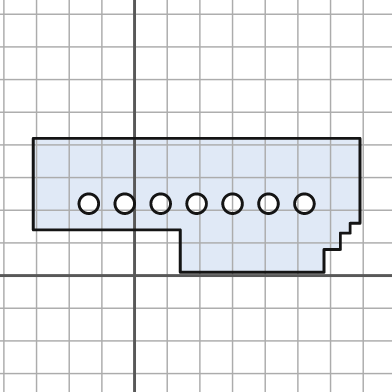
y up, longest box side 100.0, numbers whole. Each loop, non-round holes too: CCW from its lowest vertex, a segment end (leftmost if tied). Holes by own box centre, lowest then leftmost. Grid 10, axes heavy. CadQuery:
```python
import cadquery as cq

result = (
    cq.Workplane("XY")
    .moveTo(14.0, 1.0)
    .lineTo(58.0, 1.0)
    .lineTo(58.0, 8.0)
    .lineTo(63.0, 8.0)
    .lineTo(63.0, 13.0)
    .lineTo(66.0, 13.0)
    .lineTo(66.0, 16.0)
    .lineTo(69.0, 16.0)
    .lineTo(69.0, 42.0)
    .lineTo(-31.0, 42.0)
    .lineTo(-31.0, 14.0)
    .lineTo(14.0, 14.0)
    .close()
    .moveTo(-14.0, 22.0)
    .circle(3.0)
    .moveTo(-3.0, 22.0)
    .circle(3.0)
    .moveTo(8.0, 22.0)
    .circle(3.0)
    .moveTo(19.0, 22.0)
    .circle(3.0)
    .moveTo(30.0, 22.0)
    .circle(3.0)
    .moveTo(41.0, 22.0)
    .circle(3.0)
    .moveTo(52.0, 22.0)
    .circle(3.0)
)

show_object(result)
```